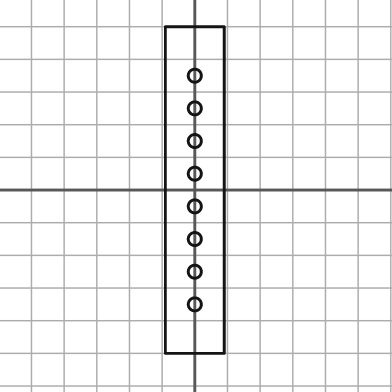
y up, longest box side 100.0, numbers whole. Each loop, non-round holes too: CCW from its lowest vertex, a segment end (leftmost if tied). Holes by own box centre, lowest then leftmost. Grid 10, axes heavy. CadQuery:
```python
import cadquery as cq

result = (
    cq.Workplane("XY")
    .moveTo(-9.0, -50.0)
    .lineTo(9.0, -50.0)
    .lineTo(9.0, 50.0)
    .lineTo(-9.0, 50.0)
    .close()
    .moveTo(0.0, -35.0)
    .circle(2.0)
    .moveTo(0.0, -25.0)
    .circle(2.0)
    .moveTo(0.0, -15.0)
    .circle(2.0)
    .moveTo(0.0, -5.0)
    .circle(2.0)
    .moveTo(0.0, 5.0)
    .circle(2.0)
    .moveTo(0.0, 15.0)
    .circle(2.0)
    .moveTo(0.0, 25.0)
    .circle(2.0)
    .moveTo(0.0, 35.0)
    .circle(2.0)
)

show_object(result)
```